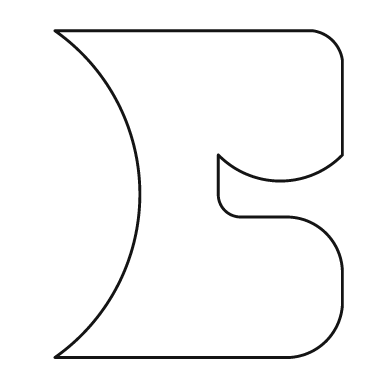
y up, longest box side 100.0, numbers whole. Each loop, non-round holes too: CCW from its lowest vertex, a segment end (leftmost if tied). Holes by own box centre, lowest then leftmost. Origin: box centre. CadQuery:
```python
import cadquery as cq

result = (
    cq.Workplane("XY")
    .moveTo(-44.0, -50.0)
    .lineTo(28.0, -50.0)
    .threePointArc((39.0, -45.0), (44.0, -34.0))
    .lineTo(44.0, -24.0)
    .threePointArc((39.0, -12.0), (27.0, -7.0))
    .lineTo(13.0, -7.0)
    .threePointArc((8.0, -5.0), (6.0, 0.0))
    .lineTo(6.0, 12.0)
    .threePointArc((25.0, 4.0), (44.0, 12.0))
    .lineTo(44.0, 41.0)
    .threePointArc((41.0, 47.0), (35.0, 50.0))
    .lineTo(-44.0, 50.0)
    .threePointArc((-18.0, 0.0), (-44.0, -50.0))
    .close()
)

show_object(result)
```